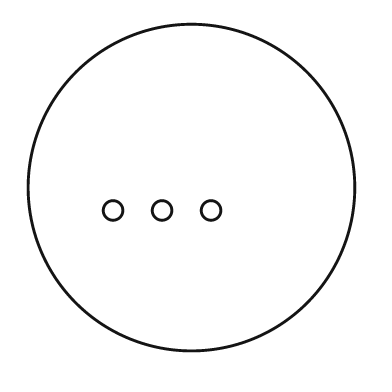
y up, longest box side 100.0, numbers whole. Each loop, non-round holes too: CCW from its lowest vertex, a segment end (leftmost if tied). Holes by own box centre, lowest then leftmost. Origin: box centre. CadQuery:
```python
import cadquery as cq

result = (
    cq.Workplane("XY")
    .moveTo(0.0, 0.0)
    .circle(50.0)
    .moveTo(-24.0, -7.0)
    .circle(3.0)
    .moveTo(-9.0, -7.0)
    .circle(3.0)
    .moveTo(6.0, -7.0)
    .circle(3.0)
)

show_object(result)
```